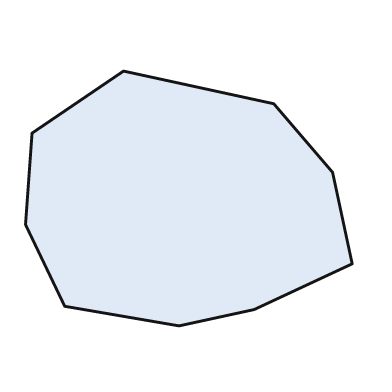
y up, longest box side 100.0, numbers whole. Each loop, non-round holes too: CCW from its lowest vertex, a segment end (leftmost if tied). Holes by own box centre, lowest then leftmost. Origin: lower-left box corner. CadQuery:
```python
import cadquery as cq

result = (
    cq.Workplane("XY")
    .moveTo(47.0, 0.0)
    .lineTo(70.0, 5.0)
    .lineTo(100.0, 19.0)
    .lineTo(94.0, 47.0)
    .lineTo(76.0, 68.0)
    .lineTo(30.0, 78.0)
    .lineTo(2.0, 59.0)
    .lineTo(0.0, 31.0)
    .lineTo(12.0, 6.0)
    .close()
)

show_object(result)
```